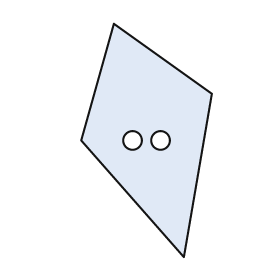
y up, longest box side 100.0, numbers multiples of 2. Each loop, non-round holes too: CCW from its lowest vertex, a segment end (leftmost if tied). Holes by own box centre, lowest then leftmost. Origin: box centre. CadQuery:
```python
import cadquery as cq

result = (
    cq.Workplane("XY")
    .moveTo(16.0, -50.0)
    .lineTo(28.0, 20.0)
    .lineTo(-14.0, 50.0)
    .lineTo(-28.0, 0.0)
    .close()
    .moveTo(-6.0, 0.0)
    .circle(4.0)
    .moveTo(6.0, 0.0)
    .circle(4.0)
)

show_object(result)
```